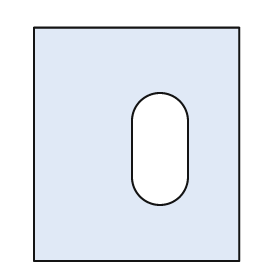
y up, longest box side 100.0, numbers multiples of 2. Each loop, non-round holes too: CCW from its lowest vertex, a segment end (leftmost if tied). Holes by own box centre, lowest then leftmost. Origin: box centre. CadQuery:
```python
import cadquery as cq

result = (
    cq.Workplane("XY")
    .moveTo(-44.0, -50.0)
    .lineTo(44.0, -50.0)
    .lineTo(44.0, 50.0)
    .lineTo(-44.0, 50.0)
    .close()
    .moveTo(-2.0, -14.0)
    .threePointArc((10.0, -26.0), (22.0, -14.0))
    .lineTo(22.0, 10.0)
    .threePointArc((10.0, 22.0), (-2.0, 10.0))
    .close()
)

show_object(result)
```